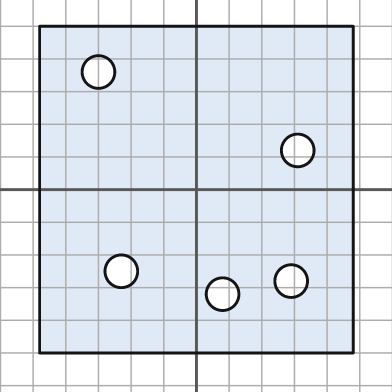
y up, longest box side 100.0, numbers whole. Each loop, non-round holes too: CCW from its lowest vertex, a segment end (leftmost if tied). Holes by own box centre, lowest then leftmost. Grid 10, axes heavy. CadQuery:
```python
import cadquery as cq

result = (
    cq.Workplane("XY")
    .moveTo(-48.0, -50.0)
    .lineTo(48.0, -50.0)
    .lineTo(48.0, 50.0)
    .lineTo(-48.0, 50.0)
    .close()
    .moveTo(8.0, -32.0)
    .circle(5.0)
    .moveTo(29.0, -28.0)
    .circle(5.0)
    .moveTo(-23.0, -25.0)
    .circle(5.0)
    .moveTo(31.0, 12.0)
    .circle(5.0)
    .moveTo(-30.0, 36.0)
    .circle(5.0)
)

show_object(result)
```